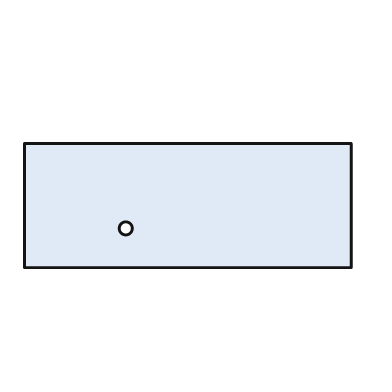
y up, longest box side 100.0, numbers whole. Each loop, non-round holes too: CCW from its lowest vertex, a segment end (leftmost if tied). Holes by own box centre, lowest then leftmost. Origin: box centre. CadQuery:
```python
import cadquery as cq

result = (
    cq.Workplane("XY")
    .moveTo(-50.0, -19.0)
    .lineTo(50.0, -19.0)
    .lineTo(50.0, 19.0)
    .lineTo(-50.0, 19.0)
    .close()
    .moveTo(-19.0, -7.0)
    .circle(2.0)
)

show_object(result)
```